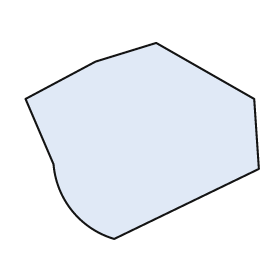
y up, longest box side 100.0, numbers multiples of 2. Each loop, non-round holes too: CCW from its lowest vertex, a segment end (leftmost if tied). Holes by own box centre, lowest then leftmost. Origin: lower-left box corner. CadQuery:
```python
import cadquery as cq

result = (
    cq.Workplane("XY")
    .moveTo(38.0, 0.0)
    .lineTo(100.0, 30.0)
    .lineTo(98.0, 60.0)
    .lineTo(56.0, 84.0)
    .lineTo(30.0, 76.0)
    .lineTo(0.0, 60.0)
    .lineTo(12.0, 32.0)
    .threePointArc((20.0, 12.0), (38.0, 0.0))
    .close()
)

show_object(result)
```